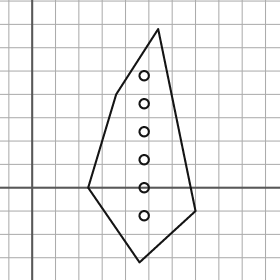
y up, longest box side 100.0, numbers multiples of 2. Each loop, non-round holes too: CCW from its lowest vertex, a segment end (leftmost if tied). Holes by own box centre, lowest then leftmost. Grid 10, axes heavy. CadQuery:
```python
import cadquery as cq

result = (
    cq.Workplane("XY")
    .moveTo(46.0, -32.0)
    .lineTo(70.0, -10.0)
    .lineTo(54.0, 68.0)
    .lineTo(36.0, 40.0)
    .lineTo(24.0, 0.0)
    .close()
    .moveTo(48.0, -12.0)
    .circle(2.0)
    .moveTo(48.0, 0.0)
    .circle(2.0)
    .moveTo(48.0, 12.0)
    .circle(2.0)
    .moveTo(48.0, 24.0)
    .circle(2.0)
    .moveTo(48.0, 36.0)
    .circle(2.0)
    .moveTo(48.0, 48.0)
    .circle(2.0)
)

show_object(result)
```